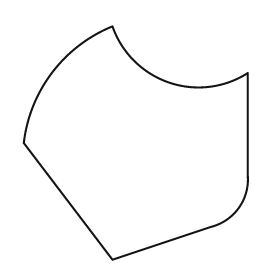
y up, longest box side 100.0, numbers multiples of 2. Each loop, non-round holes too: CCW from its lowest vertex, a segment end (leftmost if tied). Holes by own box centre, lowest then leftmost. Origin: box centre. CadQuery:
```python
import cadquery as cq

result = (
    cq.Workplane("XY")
    .moveTo(-10.0, -50.0)
    .lineTo(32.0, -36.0)
    .threePointArc((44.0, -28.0), (48.0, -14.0))
    .lineTo(48.0, 30.0)
    .threePointArc((14.0, 26.0), (-10.0, 50.0))
    .threePointArc((-36.0, 30.0), (-48.0, 0.0))
    .close()
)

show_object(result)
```